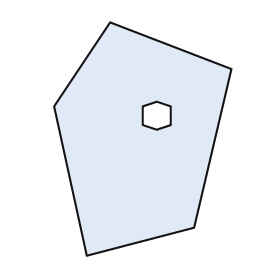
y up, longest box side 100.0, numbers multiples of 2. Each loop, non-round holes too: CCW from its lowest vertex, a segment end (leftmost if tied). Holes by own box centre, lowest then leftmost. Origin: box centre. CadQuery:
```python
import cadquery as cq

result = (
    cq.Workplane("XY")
    .moveTo(-24.0, -50.0)
    .lineTo(22.0, -38.0)
    .lineTo(38.0, 30.0)
    .lineTo(-14.0, 50.0)
    .lineTo(-38.0, 14.0)
    .close()
    .moveTo(6.0, 4.0)
    .lineTo(12.0, 6.0)
    .lineTo(12.0, 14.0)
    .lineTo(6.0, 16.0)
    .lineTo(0.0, 14.0)
    .lineTo(0.0, 6.0)
    .close()
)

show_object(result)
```